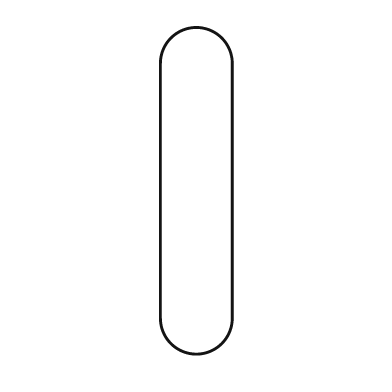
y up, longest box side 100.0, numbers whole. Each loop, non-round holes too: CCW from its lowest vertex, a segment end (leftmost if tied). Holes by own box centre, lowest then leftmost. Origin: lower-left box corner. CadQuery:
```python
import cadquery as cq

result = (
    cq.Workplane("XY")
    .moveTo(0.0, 11.0)
    .threePointArc((11.0, 0.0), (22.0, 11.0))
    .lineTo(22.0, 89.0)
    .threePointArc((11.0, 100.0), (0.0, 89.0))
    .close()
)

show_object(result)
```